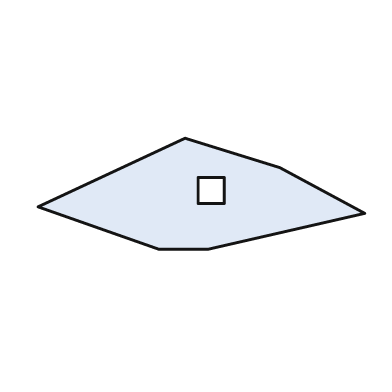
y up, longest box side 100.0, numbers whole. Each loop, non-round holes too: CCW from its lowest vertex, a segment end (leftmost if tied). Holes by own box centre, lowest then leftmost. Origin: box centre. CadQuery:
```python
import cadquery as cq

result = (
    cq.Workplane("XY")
    .moveTo(-13.0, -17.0)
    .lineTo(2.0, -17.0)
    .lineTo(50.0, -6.0)
    .lineTo(24.0, 8.0)
    .lineTo(-5.0, 17.0)
    .lineTo(-50.0, -4.0)
    .close()
    .moveTo(-1.0, -3.0)
    .lineTo(7.0, -3.0)
    .lineTo(7.0, 5.0)
    .lineTo(-1.0, 5.0)
    .close()
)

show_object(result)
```